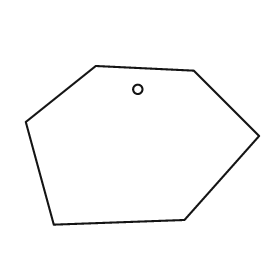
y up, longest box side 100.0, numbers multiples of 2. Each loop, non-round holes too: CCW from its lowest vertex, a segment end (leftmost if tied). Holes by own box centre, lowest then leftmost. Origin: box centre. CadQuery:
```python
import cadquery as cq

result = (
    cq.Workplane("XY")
    .moveTo(-38.0, -34.0)
    .lineTo(18.0, -32.0)
    .lineTo(50.0, 4.0)
    .lineTo(22.0, 32.0)
    .lineTo(-20.0, 34.0)
    .lineTo(-50.0, 10.0)
    .close()
    .moveTo(-2.0, 24.0)
    .circle(2.0)
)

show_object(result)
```